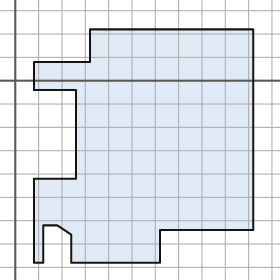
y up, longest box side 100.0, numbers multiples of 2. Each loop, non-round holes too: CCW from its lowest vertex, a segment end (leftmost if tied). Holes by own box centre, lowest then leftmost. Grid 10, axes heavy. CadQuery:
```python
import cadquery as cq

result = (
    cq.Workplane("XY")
    .moveTo(8.0, -78.0)
    .lineTo(12.0, -78.0)
    .lineTo(12.0, -62.0)
    .lineTo(18.0, -62.0)
    .lineTo(24.0, -66.0)
    .lineTo(24.0, -78.0)
    .lineTo(62.0, -78.0)
    .lineTo(62.0, -64.0)
    .lineTo(102.0, -64.0)
    .lineTo(102.0, 22.0)
    .lineTo(32.0, 22.0)
    .lineTo(32.0, 8.0)
    .lineTo(8.0, 8.0)
    .lineTo(8.0, -4.0)
    .lineTo(26.0, -4.0)
    .lineTo(26.0, -42.0)
    .lineTo(8.0, -42.0)
    .close()
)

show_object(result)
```